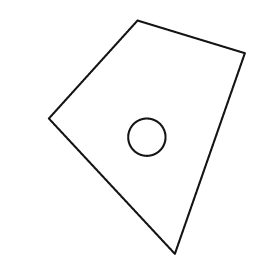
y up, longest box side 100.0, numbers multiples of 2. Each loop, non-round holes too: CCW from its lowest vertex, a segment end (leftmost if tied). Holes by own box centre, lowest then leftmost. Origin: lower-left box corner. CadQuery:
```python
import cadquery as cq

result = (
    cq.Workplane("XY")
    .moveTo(54.0, 0.0)
    .lineTo(84.0, 86.0)
    .lineTo(38.0, 100.0)
    .lineTo(0.0, 58.0)
    .close()
    .moveTo(42.0, 50.0)
    .circle(8.0)
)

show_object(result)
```